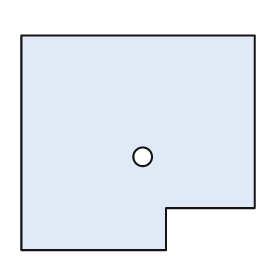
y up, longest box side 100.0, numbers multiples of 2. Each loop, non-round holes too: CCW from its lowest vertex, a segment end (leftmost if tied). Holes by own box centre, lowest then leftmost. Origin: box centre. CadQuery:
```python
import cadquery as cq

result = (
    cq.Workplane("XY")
    .moveTo(-50.0, -46.0)
    .lineTo(12.0, -46.0)
    .lineTo(12.0, -28.0)
    .lineTo(50.0, -28.0)
    .lineTo(50.0, 46.0)
    .lineTo(-50.0, 46.0)
    .close()
    .moveTo(2.0, -6.0)
    .circle(4.0)
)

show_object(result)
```